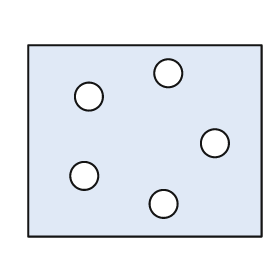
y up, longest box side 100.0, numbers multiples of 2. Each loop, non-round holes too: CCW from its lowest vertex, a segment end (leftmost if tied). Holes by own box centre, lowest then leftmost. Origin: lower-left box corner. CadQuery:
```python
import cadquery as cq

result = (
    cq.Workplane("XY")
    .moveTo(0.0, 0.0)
    .lineTo(100.0, 0.0)
    .lineTo(100.0, 82.0)
    .lineTo(0.0, 82.0)
    .close()
    .moveTo(58.0, 14.0)
    .circle(6.0)
    .moveTo(24.0, 26.0)
    .circle(6.0)
    .moveTo(80.0, 40.0)
    .circle(6.0)
    .moveTo(26.0, 60.0)
    .circle(6.0)
    .moveTo(60.0, 70.0)
    .circle(6.0)
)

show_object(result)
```